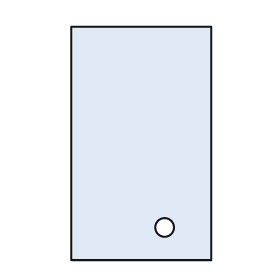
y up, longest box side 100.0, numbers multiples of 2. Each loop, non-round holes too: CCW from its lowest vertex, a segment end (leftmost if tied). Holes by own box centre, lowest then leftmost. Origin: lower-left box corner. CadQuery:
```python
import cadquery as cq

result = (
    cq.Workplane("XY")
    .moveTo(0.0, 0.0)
    .lineTo(60.0, 0.0)
    .lineTo(60.0, 100.0)
    .lineTo(0.0, 100.0)
    .close()
    .moveTo(40.0, 14.0)
    .circle(4.0)
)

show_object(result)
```